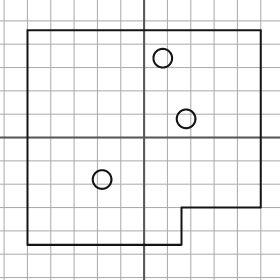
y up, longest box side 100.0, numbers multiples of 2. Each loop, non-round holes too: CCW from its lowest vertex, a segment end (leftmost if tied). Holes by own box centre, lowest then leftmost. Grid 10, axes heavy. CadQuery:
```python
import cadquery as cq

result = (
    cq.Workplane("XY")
    .moveTo(-50.0, -46.0)
    .lineTo(16.0, -46.0)
    .lineTo(16.0, -30.0)
    .lineTo(50.0, -30.0)
    .lineTo(50.0, 46.0)
    .lineTo(-50.0, 46.0)
    .close()
    .moveTo(-18.0, -18.0)
    .circle(4.0)
    .moveTo(18.0, 8.0)
    .circle(4.0)
    .moveTo(8.0, 34.0)
    .circle(4.0)
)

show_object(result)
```